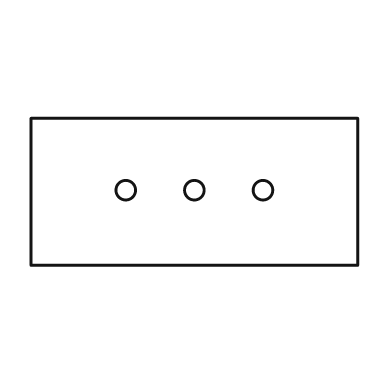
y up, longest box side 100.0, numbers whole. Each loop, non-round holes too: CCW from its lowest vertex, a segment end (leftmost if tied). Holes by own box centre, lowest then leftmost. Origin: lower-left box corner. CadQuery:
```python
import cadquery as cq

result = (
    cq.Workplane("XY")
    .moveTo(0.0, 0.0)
    .lineTo(100.0, 0.0)
    .lineTo(100.0, 45.0)
    .lineTo(0.0, 45.0)
    .close()
    .moveTo(29.0, 23.0)
    .circle(3.0)
    .moveTo(50.0, 23.0)
    .circle(3.0)
    .moveTo(71.0, 23.0)
    .circle(3.0)
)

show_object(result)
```